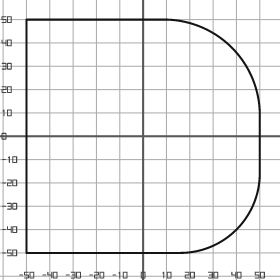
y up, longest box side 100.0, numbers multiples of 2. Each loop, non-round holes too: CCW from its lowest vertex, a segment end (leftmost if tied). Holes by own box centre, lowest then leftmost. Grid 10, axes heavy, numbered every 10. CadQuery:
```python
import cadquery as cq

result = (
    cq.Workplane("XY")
    .moveTo(-50.0, -50.0)
    .lineTo(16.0, -50.0)
    .threePointArc((40.0, -40.0), (50.0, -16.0))
    .lineTo(50.0, 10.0)
    .threePointArc((38.0, 38.0), (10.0, 50.0))
    .lineTo(-50.0, 50.0)
    .close()
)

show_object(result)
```